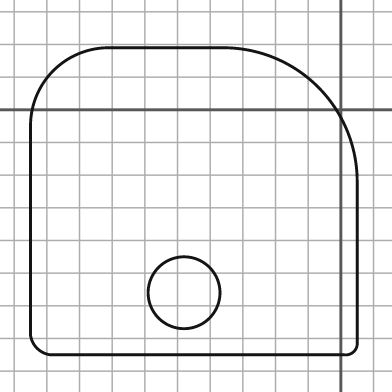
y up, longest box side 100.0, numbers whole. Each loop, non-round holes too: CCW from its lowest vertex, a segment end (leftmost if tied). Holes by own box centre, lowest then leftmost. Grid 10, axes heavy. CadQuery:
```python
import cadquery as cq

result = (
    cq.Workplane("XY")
    .moveTo(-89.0, -75.0)
    .lineTo(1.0, -75.0)
    .threePointArc((4.0, -74.0), (5.0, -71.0))
    .lineTo(5.0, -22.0)
    .threePointArc((-7.0, 7.0), (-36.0, 19.0))
    .lineTo(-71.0, 19.0)
    .threePointArc((-88.0, 12.0), (-95.0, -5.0))
    .lineTo(-95.0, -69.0)
    .threePointArc((-93.0, -73.0), (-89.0, -75.0))
    .close()
    .moveTo(-48.0, -56.0)
    .circle(11.0)
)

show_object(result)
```